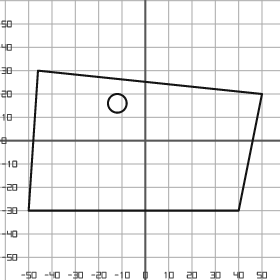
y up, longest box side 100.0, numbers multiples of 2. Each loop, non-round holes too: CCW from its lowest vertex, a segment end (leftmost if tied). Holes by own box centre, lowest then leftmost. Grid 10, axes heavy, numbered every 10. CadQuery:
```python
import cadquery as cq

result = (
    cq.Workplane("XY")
    .moveTo(-50.0, -30.0)
    .lineTo(40.0, -30.0)
    .lineTo(50.0, 20.0)
    .lineTo(-46.0, 30.0)
    .close()
    .moveTo(-12.0, 16.0)
    .circle(4.0)
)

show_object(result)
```